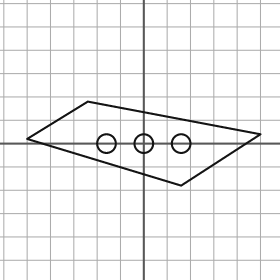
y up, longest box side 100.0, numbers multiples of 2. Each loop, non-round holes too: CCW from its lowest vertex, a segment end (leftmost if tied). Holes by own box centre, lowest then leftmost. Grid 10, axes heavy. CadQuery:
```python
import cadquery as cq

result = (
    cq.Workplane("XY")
    .moveTo(16.0, -18.0)
    .lineTo(50.0, 4.0)
    .lineTo(-24.0, 18.0)
    .lineTo(-50.0, 2.0)
    .close()
    .moveTo(-16.0, 0.0)
    .circle(4.0)
    .moveTo(0.0, 0.0)
    .circle(4.0)
    .moveTo(16.0, 0.0)
    .circle(4.0)
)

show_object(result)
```